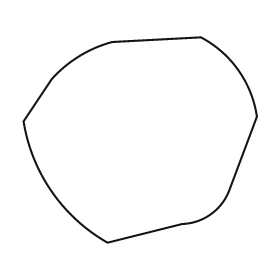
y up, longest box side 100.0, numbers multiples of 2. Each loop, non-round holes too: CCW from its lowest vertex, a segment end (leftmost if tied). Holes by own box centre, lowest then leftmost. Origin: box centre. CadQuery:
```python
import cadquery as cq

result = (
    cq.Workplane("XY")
    .moveTo(-14.0, -44.0)
    .lineTo(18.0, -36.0)
    .threePointArc((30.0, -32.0), (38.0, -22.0))
    .lineTo(50.0, 10.0)
    .threePointArc((42.0, 30.0), (26.0, 44.0))
    .lineTo(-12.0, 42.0)
    .threePointArc((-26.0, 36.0), (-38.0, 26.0))
    .lineTo(-50.0, 8.0)
    .threePointArc((-38.0, -22.0), (-14.0, -44.0))
    .close()
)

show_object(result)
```